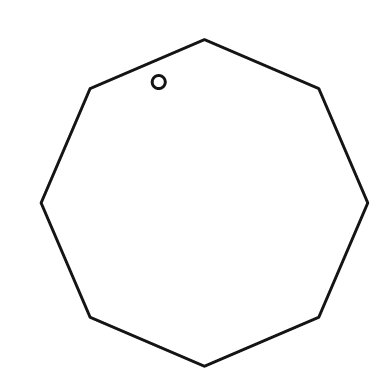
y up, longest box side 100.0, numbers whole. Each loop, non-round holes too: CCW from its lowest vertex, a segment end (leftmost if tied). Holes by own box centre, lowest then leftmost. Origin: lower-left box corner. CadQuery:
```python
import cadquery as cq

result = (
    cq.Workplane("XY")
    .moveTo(50.0, 0.0)
    .lineTo(85.0, 15.0)
    .lineTo(100.0, 50.0)
    .lineTo(85.0, 85.0)
    .lineTo(50.0, 100.0)
    .lineTo(15.0, 85.0)
    .lineTo(0.0, 50.0)
    .lineTo(15.0, 15.0)
    .close()
    .moveTo(36.0, 87.0)
    .circle(2.0)
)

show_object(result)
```